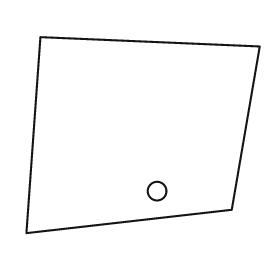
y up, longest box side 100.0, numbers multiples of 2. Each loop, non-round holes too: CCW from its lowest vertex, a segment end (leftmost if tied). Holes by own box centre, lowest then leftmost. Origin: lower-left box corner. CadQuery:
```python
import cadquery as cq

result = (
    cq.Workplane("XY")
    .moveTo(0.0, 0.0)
    .lineTo(88.0, 10.0)
    .lineTo(100.0, 80.0)
    .lineTo(6.0, 84.0)
    .close()
    .moveTo(56.0, 18.0)
    .circle(4.0)
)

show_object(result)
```